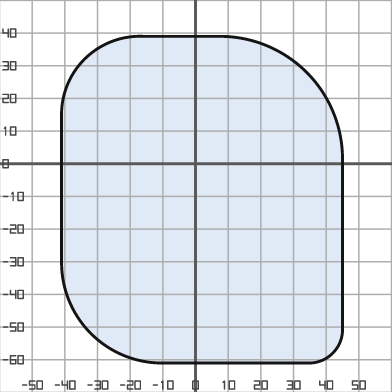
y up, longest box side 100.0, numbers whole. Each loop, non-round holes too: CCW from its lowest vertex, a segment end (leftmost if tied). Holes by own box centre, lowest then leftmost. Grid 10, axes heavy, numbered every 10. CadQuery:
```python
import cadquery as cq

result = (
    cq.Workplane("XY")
    .moveTo(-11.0, -61.0)
    .lineTo(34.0, -61.0)
    .threePointArc((42.0, -58.0), (45.0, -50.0))
    .lineTo(45.0, 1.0)
    .threePointArc((34.0, 28.0), (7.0, 39.0))
    .lineTo(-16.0, 39.0)
    .threePointArc((-34.0, 32.0), (-41.0, 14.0))
    .lineTo(-41.0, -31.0)
    .threePointArc((-32.0, -52.0), (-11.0, -61.0))
    .close()
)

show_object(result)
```